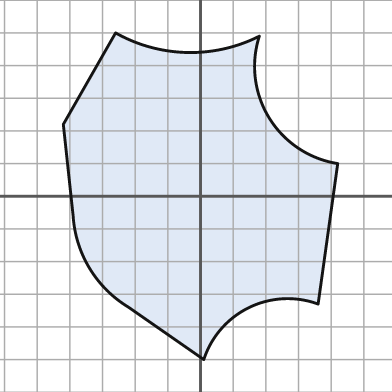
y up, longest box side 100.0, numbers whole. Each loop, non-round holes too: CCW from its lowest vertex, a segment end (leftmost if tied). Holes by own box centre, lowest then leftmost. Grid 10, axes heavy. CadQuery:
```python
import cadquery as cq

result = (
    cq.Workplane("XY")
    .moveTo(1.0, -50.0)
    .threePointArc((15.0, -34.0), (36.0, -33.0))
    .lineTo(42.0, 10.0)
    .threePointArc((21.0, 24.0), (18.0, 49.0))
    .threePointArc((-4.0, 44.0), (-26.0, 50.0))
    .lineTo(-42.0, 22.0)
    .lineTo(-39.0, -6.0)
    .threePointArc((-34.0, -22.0), (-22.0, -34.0))
    .close()
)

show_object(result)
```